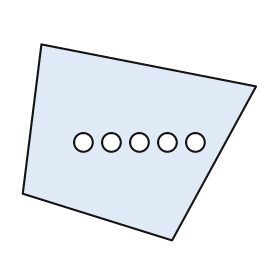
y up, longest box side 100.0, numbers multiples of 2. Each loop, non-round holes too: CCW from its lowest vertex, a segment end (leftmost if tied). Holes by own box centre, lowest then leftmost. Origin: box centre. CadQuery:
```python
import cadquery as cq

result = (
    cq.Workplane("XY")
    .moveTo(14.0, -42.0)
    .lineTo(50.0, 24.0)
    .lineTo(-42.0, 42.0)
    .lineTo(-50.0, -22.0)
    .close()
    .moveTo(-24.0, 0.0)
    .circle(4.0)
    .moveTo(-12.0, 0.0)
    .circle(4.0)
    .moveTo(0.0, 0.0)
    .circle(4.0)
    .moveTo(12.0, 0.0)
    .circle(4.0)
    .moveTo(24.0, 0.0)
    .circle(4.0)
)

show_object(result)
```